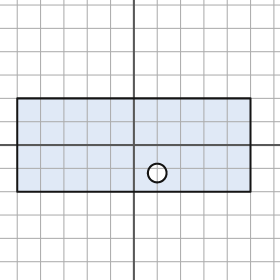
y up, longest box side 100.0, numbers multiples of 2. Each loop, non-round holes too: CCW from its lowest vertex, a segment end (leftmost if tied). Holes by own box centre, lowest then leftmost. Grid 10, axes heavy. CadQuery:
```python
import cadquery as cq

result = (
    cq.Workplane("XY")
    .moveTo(-50.0, -20.0)
    .lineTo(50.0, -20.0)
    .lineTo(50.0, 20.0)
    .lineTo(-50.0, 20.0)
    .close()
    .moveTo(10.0, -12.0)
    .circle(4.0)
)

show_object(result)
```